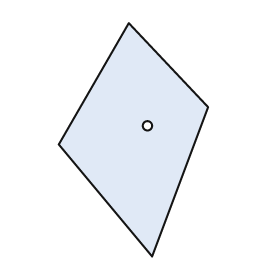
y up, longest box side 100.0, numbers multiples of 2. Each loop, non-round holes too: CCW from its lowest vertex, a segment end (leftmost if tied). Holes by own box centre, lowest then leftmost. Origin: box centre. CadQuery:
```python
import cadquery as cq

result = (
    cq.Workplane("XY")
    .moveTo(8.0, -50.0)
    .lineTo(32.0, 14.0)
    .lineTo(-2.0, 50.0)
    .lineTo(-32.0, -2.0)
    .close()
    .moveTo(6.0, 6.0)
    .circle(2.0)
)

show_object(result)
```